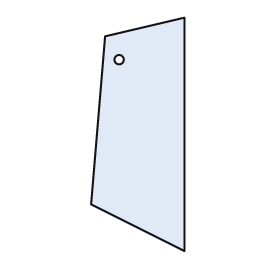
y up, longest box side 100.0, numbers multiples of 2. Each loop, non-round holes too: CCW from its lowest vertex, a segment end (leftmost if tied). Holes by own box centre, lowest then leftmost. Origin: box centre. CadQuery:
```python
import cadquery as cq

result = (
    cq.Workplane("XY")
    .moveTo(20.0, -50.0)
    .lineTo(20.0, 50.0)
    .lineTo(-14.0, 42.0)
    .lineTo(-20.0, -30.0)
    .close()
    .moveTo(-8.0, 32.0)
    .circle(2.0)
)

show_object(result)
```